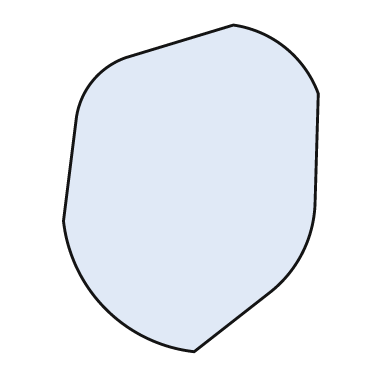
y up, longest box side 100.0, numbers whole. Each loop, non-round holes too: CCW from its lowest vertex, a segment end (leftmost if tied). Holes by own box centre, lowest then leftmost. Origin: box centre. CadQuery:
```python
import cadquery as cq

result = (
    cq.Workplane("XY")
    .moveTo(1.0, -50.0)
    .lineTo(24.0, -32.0)
    .threePointArc((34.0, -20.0), (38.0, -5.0))
    .lineTo(39.0, 29.0)
    .threePointArc((29.0, 43.0), (13.0, 50.0))
    .lineTo(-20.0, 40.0)
    .threePointArc((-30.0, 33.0), (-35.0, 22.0))
    .lineTo(-39.0, -10.0)
    .threePointArc((-26.0, -37.0), (1.0, -50.0))
    .close()
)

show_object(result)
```